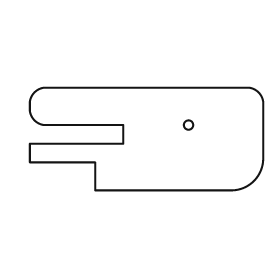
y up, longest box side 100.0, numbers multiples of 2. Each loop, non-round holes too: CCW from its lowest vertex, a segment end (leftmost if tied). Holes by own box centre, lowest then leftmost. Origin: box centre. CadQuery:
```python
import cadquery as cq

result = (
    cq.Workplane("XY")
    .moveTo(-22.0, -22.0)
    .lineTo(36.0, -22.0)
    .threePointArc((46.0, -18.0), (50.0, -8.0))
    .lineTo(50.0, 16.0)
    .threePointArc((48.0, 20.0), (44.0, 22.0))
    .lineTo(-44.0, 22.0)
    .threePointArc((-48.0, 20.0), (-50.0, 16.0))
    .lineTo(-50.0, 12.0)
    .threePointArc((-48.0, 8.0), (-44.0, 6.0))
    .lineTo(-10.0, 6.0)
    .lineTo(-10.0, -2.0)
    .lineTo(-50.0, -2.0)
    .lineTo(-50.0, -10.0)
    .lineTo(-22.0, -10.0)
    .close()
    .moveTo(18.0, 6.0)
    .circle(2.0)
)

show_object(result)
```